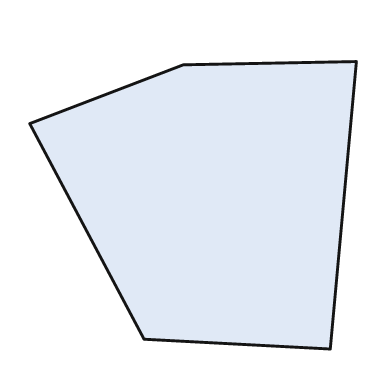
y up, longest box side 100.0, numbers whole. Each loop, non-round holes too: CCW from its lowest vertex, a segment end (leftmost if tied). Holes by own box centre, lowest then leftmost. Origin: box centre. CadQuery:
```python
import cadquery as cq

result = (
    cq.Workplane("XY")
    .moveTo(42.0, -44.0)
    .lineTo(50.0, 44.0)
    .lineTo(-3.0, 43.0)
    .lineTo(-50.0, 25.0)
    .lineTo(-15.0, -41.0)
    .close()
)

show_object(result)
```